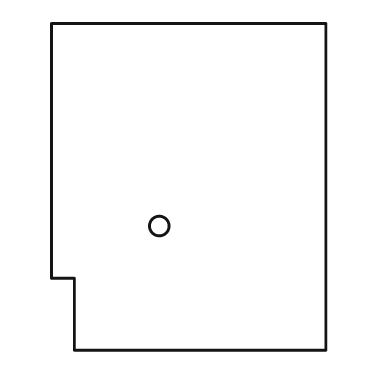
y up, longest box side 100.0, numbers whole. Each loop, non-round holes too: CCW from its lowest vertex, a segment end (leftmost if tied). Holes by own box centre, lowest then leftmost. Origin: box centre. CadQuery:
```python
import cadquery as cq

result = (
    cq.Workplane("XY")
    .moveTo(-35.0, -50.0)
    .lineTo(42.0, -50.0)
    .lineTo(42.0, 50.0)
    .lineTo(-42.0, 50.0)
    .lineTo(-42.0, -28.0)
    .lineTo(-35.0, -28.0)
    .close()
    .moveTo(-9.0, -12.0)
    .circle(3.0)
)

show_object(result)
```